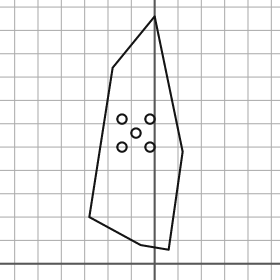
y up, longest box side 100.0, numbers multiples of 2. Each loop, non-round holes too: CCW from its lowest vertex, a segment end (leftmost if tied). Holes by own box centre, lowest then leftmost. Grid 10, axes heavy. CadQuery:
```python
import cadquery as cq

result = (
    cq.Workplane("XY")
    .moveTo(6.0, 6.0)
    .lineTo(12.0, 48.0)
    .lineTo(0.0, 106.0)
    .lineTo(-18.0, 84.0)
    .lineTo(-28.0, 20.0)
    .lineTo(-6.0, 8.0)
    .close()
    .moveTo(-14.0, 50.0)
    .circle(2.0)
    .moveTo(-2.0, 50.0)
    .circle(2.0)
    .moveTo(-8.0, 56.0)
    .circle(2.0)
    .moveTo(-14.0, 62.0)
    .circle(2.0)
    .moveTo(-2.0, 62.0)
    .circle(2.0)
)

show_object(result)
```